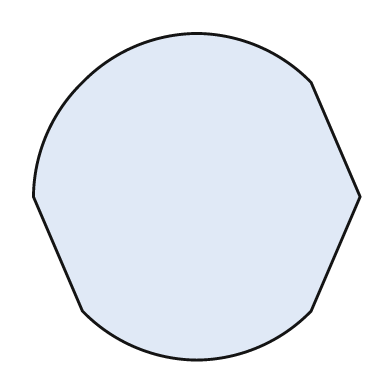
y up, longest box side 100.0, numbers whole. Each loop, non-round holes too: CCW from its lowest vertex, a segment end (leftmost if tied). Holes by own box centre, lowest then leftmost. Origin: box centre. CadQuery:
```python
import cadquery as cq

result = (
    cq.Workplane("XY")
    .moveTo(0.0, -50.0)
    .threePointArc((19.0, -46.0), (35.0, -35.0))
    .lineTo(50.0, 0.0)
    .lineTo(35.0, 35.0)
    .threePointArc((19.0, 46.0), (0.0, 50.0))
    .threePointArc((-19.0, 46.0), (-35.0, 35.0))
    .threePointArc((-46.0, 19.0), (-50.0, 0.0))
    .lineTo(-35.0, -35.0)
    .threePointArc((-19.0, -46.0), (0.0, -50.0))
    .close()
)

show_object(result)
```